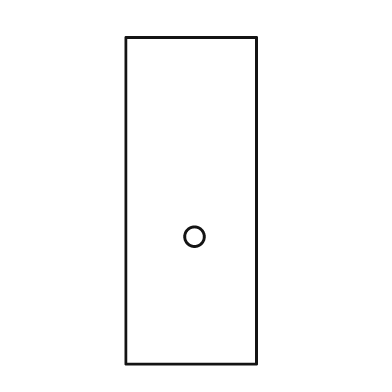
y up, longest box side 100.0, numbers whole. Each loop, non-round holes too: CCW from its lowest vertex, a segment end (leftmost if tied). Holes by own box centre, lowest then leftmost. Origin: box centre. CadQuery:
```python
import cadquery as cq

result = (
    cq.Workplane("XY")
    .moveTo(-20.0, -50.0)
    .lineTo(20.0, -50.0)
    .lineTo(20.0, 50.0)
    .lineTo(-20.0, 50.0)
    .close()
    .moveTo(1.0, -11.0)
    .circle(3.0)
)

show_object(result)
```